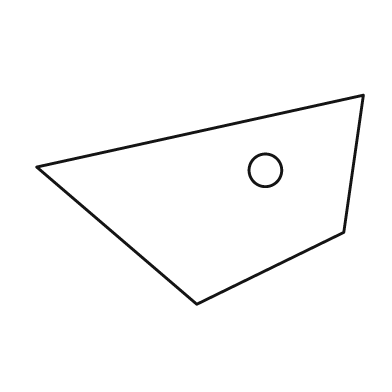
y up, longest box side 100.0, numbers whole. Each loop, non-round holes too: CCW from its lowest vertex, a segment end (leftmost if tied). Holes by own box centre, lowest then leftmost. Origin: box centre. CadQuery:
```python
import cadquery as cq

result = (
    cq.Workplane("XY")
    .moveTo(-1.0, -32.0)
    .lineTo(44.0, -10.0)
    .lineTo(50.0, 32.0)
    .lineTo(-50.0, 10.0)
    .close()
    .moveTo(20.0, 9.0)
    .circle(5.0)
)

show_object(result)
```